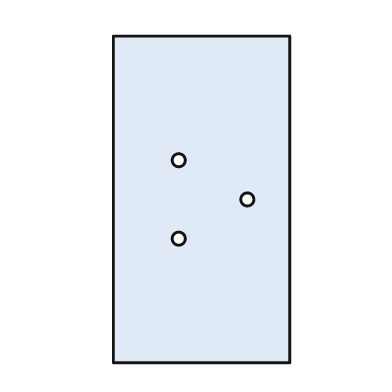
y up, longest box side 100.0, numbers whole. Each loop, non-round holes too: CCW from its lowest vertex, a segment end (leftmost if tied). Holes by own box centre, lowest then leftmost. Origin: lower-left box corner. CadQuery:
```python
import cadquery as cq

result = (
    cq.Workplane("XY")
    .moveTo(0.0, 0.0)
    .lineTo(54.0, 0.0)
    .lineTo(54.0, 100.0)
    .lineTo(0.0, 100.0)
    .close()
    .moveTo(20.0, 38.0)
    .circle(2.0)
    .moveTo(41.0, 50.0)
    .circle(2.0)
    .moveTo(20.0, 62.0)
    .circle(2.0)
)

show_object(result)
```